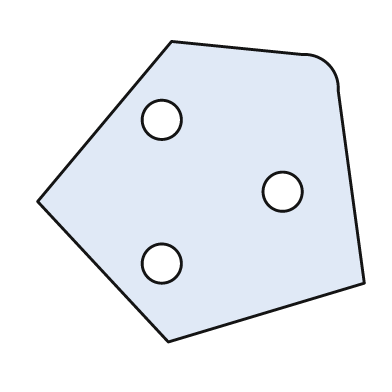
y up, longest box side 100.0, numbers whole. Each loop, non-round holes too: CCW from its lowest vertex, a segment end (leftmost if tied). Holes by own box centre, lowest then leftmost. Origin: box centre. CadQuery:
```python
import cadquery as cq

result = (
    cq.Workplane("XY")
    .moveTo(-10.0, -46.0)
    .lineTo(50.0, -28.0)
    .lineTo(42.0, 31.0)
    .threePointArc((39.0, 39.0), (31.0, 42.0))
    .lineTo(-9.0, 46.0)
    .lineTo(-50.0, -3.0)
    .close()
    .moveTo(-12.0, -22.0)
    .circle(6.0)
    .moveTo(25.0, 0.0)
    .circle(6.0)
    .moveTo(-12.0, 22.0)
    .circle(6.0)
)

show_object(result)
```